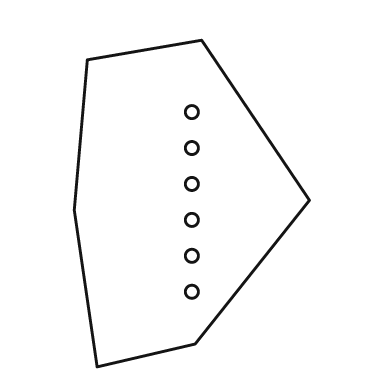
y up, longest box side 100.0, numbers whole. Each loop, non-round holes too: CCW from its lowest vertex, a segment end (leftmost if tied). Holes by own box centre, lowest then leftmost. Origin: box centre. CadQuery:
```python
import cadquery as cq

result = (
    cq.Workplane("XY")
    .moveTo(-29.0, -50.0)
    .lineTo(1.0, -43.0)
    .lineTo(36.0, 1.0)
    .lineTo(3.0, 50.0)
    .lineTo(-32.0, 44.0)
    .lineTo(-36.0, -2.0)
    .close()
    .moveTo(0.0, -27.0)
    .circle(2.0)
    .moveTo(0.0, -16.0)
    .circle(2.0)
    .moveTo(0.0, -5.0)
    .circle(2.0)
    .moveTo(0.0, 6.0)
    .circle(2.0)
    .moveTo(0.0, 17.0)
    .circle(2.0)
    .moveTo(0.0, 28.0)
    .circle(2.0)
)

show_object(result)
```